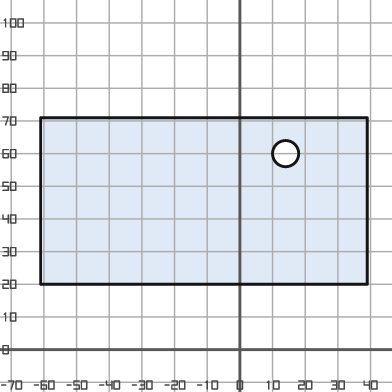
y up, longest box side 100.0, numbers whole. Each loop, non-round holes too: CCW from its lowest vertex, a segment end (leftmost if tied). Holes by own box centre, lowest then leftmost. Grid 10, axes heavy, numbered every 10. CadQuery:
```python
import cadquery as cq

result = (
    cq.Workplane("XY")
    .moveTo(-61.0, 20.0)
    .lineTo(39.0, 20.0)
    .lineTo(39.0, 71.0)
    .lineTo(-61.0, 71.0)
    .close()
    .moveTo(14.0, 60.0)
    .circle(4.0)
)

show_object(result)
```